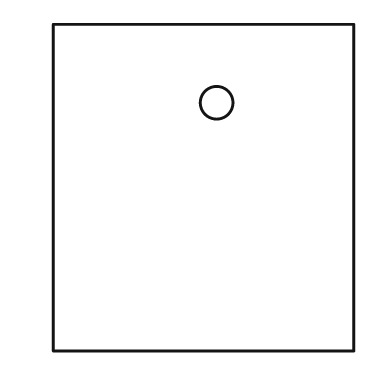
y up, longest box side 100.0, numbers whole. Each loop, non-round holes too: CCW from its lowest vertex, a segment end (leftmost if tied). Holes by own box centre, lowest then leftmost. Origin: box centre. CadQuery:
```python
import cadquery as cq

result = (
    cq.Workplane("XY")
    .moveTo(-46.0, -50.0)
    .lineTo(46.0, -50.0)
    .lineTo(46.0, 50.0)
    .lineTo(-46.0, 50.0)
    .close()
    .moveTo(4.0, 26.0)
    .circle(5.0)
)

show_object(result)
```